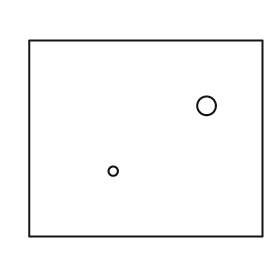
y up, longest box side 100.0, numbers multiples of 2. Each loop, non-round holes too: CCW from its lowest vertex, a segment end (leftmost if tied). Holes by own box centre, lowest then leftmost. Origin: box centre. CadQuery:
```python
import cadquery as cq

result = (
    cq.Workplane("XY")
    .moveTo(-50.0, -42.0)
    .lineTo(50.0, -42.0)
    .lineTo(50.0, 42.0)
    .lineTo(-50.0, 42.0)
    .close()
    .moveTo(-14.0, -14.0)
    .circle(2.0)
    .moveTo(26.0, 14.0)
    .circle(4.0)
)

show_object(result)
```